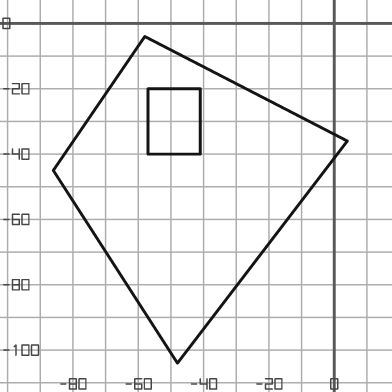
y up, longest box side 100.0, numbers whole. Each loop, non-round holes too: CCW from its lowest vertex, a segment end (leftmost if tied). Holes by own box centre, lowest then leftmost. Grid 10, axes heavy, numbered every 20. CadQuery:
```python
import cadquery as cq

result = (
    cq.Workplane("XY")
    .moveTo(-48.0, -104.0)
    .lineTo(4.0, -36.0)
    .lineTo(-58.0, -4.0)
    .lineTo(-86.0, -45.0)
    .close()
    .moveTo(-57.0, -40.0)
    .lineTo(-41.0, -40.0)
    .lineTo(-41.0, -20.0)
    .lineTo(-57.0, -20.0)
    .close()
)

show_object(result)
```